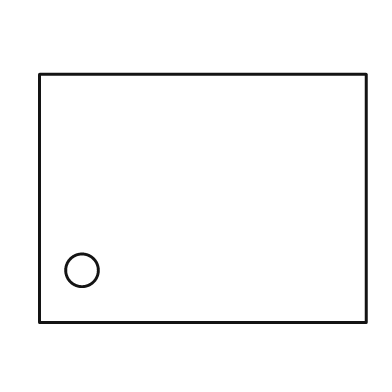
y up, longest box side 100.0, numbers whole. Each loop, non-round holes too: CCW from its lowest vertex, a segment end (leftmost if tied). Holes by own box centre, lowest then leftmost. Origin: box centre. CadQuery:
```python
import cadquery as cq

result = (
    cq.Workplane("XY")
    .moveTo(-50.0, -38.0)
    .lineTo(50.0, -38.0)
    .lineTo(50.0, 38.0)
    .lineTo(-50.0, 38.0)
    .close()
    .moveTo(-37.0, -22.0)
    .circle(5.0)
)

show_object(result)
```